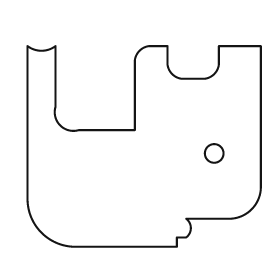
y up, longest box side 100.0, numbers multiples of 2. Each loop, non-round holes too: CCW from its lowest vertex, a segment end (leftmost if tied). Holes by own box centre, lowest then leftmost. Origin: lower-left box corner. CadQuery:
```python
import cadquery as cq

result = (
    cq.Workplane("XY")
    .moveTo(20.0, 0.0)
    .lineTo(64.0, 0.0)
    .lineTo(64.0, 4.0)
    .lineTo(68.0, 4.0)
    .threePointArc((70.0, 8.0), (68.0, 12.0))
    .lineTo(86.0, 12.0)
    .threePointArc((96.0, 16.0), (100.0, 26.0))
    .lineTo(100.0, 86.0)
    .lineTo(82.0, 86.0)
    .lineTo(82.0, 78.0)
    .threePointArc((80.0, 74.0), (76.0, 72.0))
    .lineTo(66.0, 72.0)
    .threePointArc((62.0, 74.0), (60.0, 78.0))
    .lineTo(60.0, 86.0)
    .lineTo(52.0, 86.0)
    .threePointArc((48.0, 84.0), (46.0, 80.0))
    .lineTo(46.0, 50.0)
    .lineTo(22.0, 50.0)
    .threePointArc((14.0, 52.0), (12.0, 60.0))
    .lineTo(12.0, 86.0)
    .threePointArc((6.0, 84.0), (0.0, 86.0))
    .lineTo(0.0, 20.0)
    .threePointArc((6.0, 6.0), (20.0, 0.0))
    .close()
    .moveTo(80.0, 40.0)
    .circle(4.0)
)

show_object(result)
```